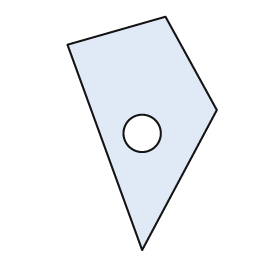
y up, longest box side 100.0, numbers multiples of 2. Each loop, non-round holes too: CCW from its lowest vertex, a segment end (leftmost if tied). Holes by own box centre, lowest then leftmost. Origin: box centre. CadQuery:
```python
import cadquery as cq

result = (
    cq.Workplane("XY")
    .moveTo(0.0, -50.0)
    .lineTo(32.0, 10.0)
    .lineTo(10.0, 50.0)
    .lineTo(-32.0, 38.0)
    .close()
    .moveTo(0.0, 0.0)
    .circle(8.0)
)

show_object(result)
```